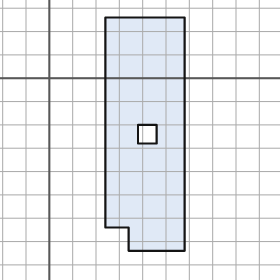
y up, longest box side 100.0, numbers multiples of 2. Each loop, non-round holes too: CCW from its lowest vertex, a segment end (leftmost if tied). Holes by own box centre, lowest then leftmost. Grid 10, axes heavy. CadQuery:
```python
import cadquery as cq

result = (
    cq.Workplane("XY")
    .moveTo(34.0, -74.0)
    .lineTo(58.0, -74.0)
    .lineTo(58.0, 26.0)
    .lineTo(24.0, 26.0)
    .lineTo(24.0, -64.0)
    .lineTo(34.0, -64.0)
    .close()
    .moveTo(38.0, -28.0)
    .lineTo(46.0, -28.0)
    .lineTo(46.0, -20.0)
    .lineTo(38.0, -20.0)
    .close()
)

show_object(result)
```